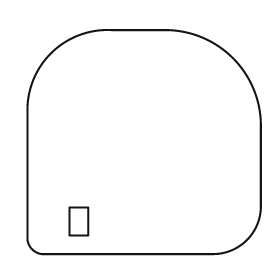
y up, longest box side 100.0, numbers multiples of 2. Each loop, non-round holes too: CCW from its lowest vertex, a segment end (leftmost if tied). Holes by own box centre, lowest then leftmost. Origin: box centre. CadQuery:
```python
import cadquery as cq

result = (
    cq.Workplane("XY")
    .moveTo(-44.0, -48.0)
    .lineTo(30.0, -48.0)
    .threePointArc((44.0, -42.0), (50.0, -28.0))
    .lineTo(50.0, 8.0)
    .threePointArc((38.0, 36.0), (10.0, 48.0))
    .lineTo(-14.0, 48.0)
    .threePointArc((-40.0, 38.0), (-50.0, 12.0))
    .lineTo(-50.0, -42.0)
    .threePointArc((-48.0, -46.0), (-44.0, -48.0))
    .close()
    .moveTo(-32.0, -40.0)
    .lineTo(-24.0, -40.0)
    .lineTo(-24.0, -28.0)
    .lineTo(-32.0, -28.0)
    .close()
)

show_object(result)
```